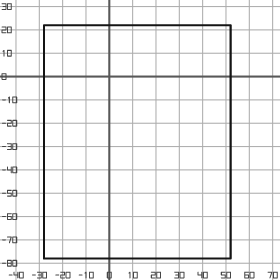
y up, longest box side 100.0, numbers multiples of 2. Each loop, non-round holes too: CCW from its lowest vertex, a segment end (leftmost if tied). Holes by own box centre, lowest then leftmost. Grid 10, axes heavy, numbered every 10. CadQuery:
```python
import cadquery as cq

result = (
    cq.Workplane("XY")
    .moveTo(-28.0, -78.0)
    .lineTo(52.0, -78.0)
    .lineTo(52.0, 22.0)
    .lineTo(-28.0, 22.0)
    .close()
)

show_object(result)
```